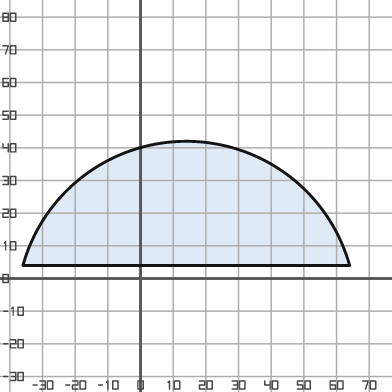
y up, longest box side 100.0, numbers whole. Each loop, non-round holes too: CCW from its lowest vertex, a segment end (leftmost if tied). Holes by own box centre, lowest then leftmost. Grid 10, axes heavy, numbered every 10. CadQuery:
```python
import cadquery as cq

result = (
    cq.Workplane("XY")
    .moveTo(-36.0, 4.0)
    .lineTo(64.0, 4.0)
    .threePointArc((14.0, 42.0), (-36.0, 4.0))
    .close()
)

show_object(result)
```